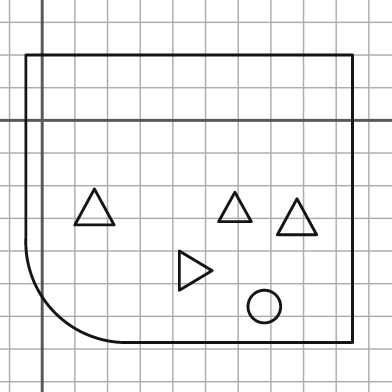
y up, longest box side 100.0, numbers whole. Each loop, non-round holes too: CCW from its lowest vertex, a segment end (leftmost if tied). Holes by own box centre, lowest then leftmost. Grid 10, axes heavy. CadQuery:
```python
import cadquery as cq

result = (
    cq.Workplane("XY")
    .moveTo(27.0, -68.0)
    .lineTo(95.0, -68.0)
    .lineTo(95.0, 20.0)
    .lineTo(-5.0, 20.0)
    .lineTo(-5.0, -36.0)
    .threePointArc((4.0, -59.0), (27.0, -68.0))
    .close()
    .moveTo(68.0, -57.0)
    .circle(5.0)
    .moveTo(42.0, -52.0)
    .lineTo(52.0, -46.0)
    .lineTo(42.0, -40.0)
    .close()
    .moveTo(72.0, -35.0)
    .lineTo(84.0, -35.0)
    .lineTo(78.0, -24.0)
    .close()
    .moveTo(10.0, -32.0)
    .lineTo(22.0, -32.0)
    .lineTo(16.0, -21.0)
    .close()
    .moveTo(54.0, -31.0)
    .lineTo(64.0, -31.0)
    .lineTo(59.0, -22.0)
    .close()
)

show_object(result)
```